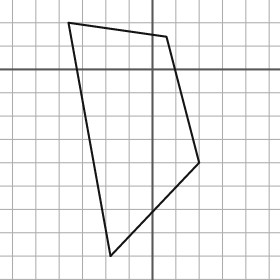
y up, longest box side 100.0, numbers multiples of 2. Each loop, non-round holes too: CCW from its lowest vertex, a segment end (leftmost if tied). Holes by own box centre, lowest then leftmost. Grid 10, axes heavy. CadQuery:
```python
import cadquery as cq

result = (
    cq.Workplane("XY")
    .moveTo(-18.0, -80.0)
    .lineTo(20.0, -40.0)
    .lineTo(6.0, 14.0)
    .lineTo(-36.0, 20.0)
    .close()
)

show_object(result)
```